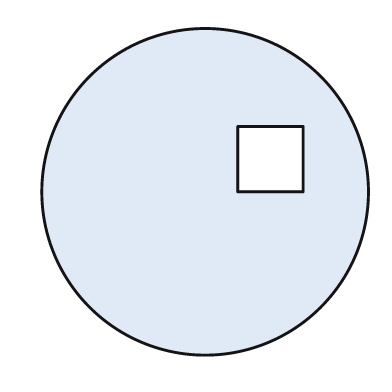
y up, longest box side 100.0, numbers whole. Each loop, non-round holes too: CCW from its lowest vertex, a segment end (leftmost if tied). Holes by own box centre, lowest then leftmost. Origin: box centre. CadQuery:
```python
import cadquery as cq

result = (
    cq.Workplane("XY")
    .moveTo(0.0, 0.0)
    .circle(50.0)
    .moveTo(10.0, 0.0)
    .lineTo(30.0, 0.0)
    .lineTo(30.0, 20.0)
    .lineTo(10.0, 20.0)
    .close()
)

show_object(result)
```